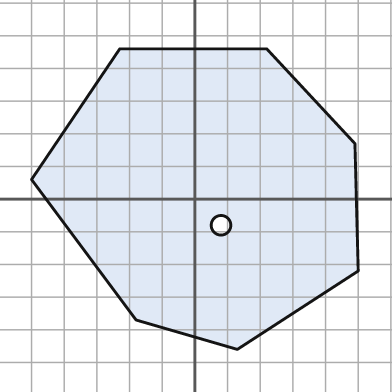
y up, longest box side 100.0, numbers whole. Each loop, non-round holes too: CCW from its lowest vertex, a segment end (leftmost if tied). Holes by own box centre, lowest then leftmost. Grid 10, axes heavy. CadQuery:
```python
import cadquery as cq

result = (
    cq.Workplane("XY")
    .moveTo(13.0, -46.0)
    .lineTo(50.0, -22.0)
    .lineTo(49.0, 17.0)
    .lineTo(22.0, 46.0)
    .lineTo(-23.0, 46.0)
    .lineTo(-50.0, 6.0)
    .lineTo(-18.0, -37.0)
    .close()
    .moveTo(8.0, -8.0)
    .circle(3.0)
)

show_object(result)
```